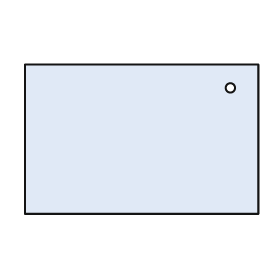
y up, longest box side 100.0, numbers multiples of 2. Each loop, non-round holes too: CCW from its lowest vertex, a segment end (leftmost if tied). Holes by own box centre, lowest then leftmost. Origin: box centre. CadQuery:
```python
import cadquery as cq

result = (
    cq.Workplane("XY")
    .moveTo(-50.0, -32.0)
    .lineTo(50.0, -32.0)
    .lineTo(50.0, 32.0)
    .lineTo(-50.0, 32.0)
    .close()
    .moveTo(38.0, 22.0)
    .circle(2.0)
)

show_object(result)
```